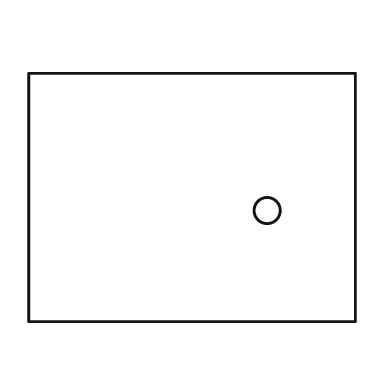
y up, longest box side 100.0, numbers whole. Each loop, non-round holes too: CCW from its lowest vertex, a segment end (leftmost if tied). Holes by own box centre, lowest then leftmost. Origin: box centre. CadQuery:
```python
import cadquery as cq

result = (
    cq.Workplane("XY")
    .moveTo(-50.0, -38.0)
    .lineTo(50.0, -38.0)
    .lineTo(50.0, 38.0)
    .lineTo(-50.0, 38.0)
    .close()
    .moveTo(23.0, -4.0)
    .circle(4.0)
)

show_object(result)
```